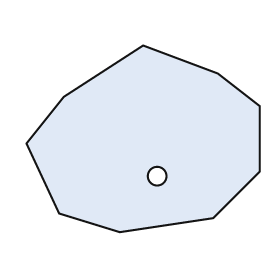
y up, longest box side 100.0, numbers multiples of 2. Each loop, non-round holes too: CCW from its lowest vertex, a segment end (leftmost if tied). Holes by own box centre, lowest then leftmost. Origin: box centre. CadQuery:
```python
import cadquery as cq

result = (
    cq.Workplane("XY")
    .moveTo(-10.0, -40.0)
    .lineTo(30.0, -34.0)
    .lineTo(50.0, -14.0)
    .lineTo(50.0, 14.0)
    .lineTo(32.0, 28.0)
    .lineTo(0.0, 40.0)
    .lineTo(-34.0, 18.0)
    .lineTo(-50.0, -2.0)
    .lineTo(-36.0, -32.0)
    .close()
    .moveTo(6.0, -16.0)
    .circle(4.0)
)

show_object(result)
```